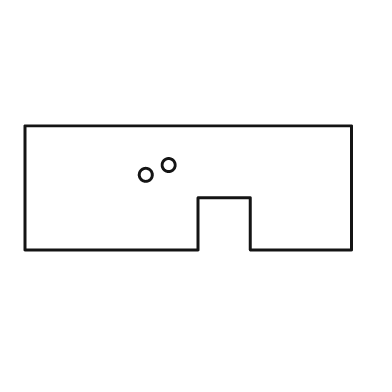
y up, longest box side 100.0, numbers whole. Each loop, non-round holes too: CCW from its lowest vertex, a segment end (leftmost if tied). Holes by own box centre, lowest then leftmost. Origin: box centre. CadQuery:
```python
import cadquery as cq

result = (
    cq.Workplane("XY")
    .moveTo(-50.0, -19.0)
    .lineTo(3.0, -19.0)
    .lineTo(3.0, -3.0)
    .lineTo(19.0, -3.0)
    .lineTo(19.0, -19.0)
    .lineTo(50.0, -19.0)
    .lineTo(50.0, 19.0)
    .lineTo(-50.0, 19.0)
    .close()
    .moveTo(-13.0, 4.0)
    .circle(2.0)
    .moveTo(-6.0, 7.0)
    .circle(2.0)
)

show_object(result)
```